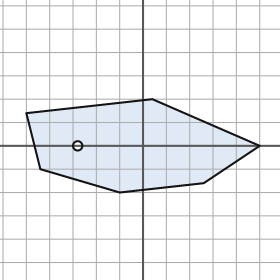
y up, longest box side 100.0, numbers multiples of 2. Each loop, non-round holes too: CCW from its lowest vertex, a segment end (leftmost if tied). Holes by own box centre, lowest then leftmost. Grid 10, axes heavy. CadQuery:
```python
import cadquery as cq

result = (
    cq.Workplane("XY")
    .moveTo(-10.0, -20.0)
    .lineTo(26.0, -16.0)
    .lineTo(50.0, 0.0)
    .lineTo(4.0, 20.0)
    .lineTo(-50.0, 14.0)
    .lineTo(-44.0, -10.0)
    .close()
    .moveTo(-28.0, 0.0)
    .circle(2.0)
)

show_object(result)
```